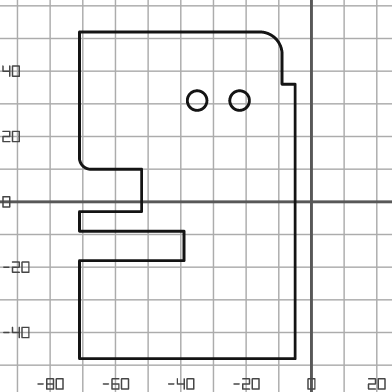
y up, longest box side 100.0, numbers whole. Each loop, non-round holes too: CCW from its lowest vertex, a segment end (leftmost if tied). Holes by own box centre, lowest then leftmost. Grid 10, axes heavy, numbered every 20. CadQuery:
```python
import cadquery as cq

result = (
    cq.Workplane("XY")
    .moveTo(-71.0, -48.0)
    .lineTo(-5.0, -48.0)
    .lineTo(-5.0, 36.0)
    .lineTo(-9.0, 36.0)
    .lineTo(-9.0, 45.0)
    .threePointArc((-11.0, 50.0), (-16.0, 52.0))
    .lineTo(-71.0, 52.0)
    .lineTo(-71.0, 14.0)
    .threePointArc((-70.0, 11.0), (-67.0, 10.0))
    .lineTo(-52.0, 10.0)
    .lineTo(-52.0, -3.0)
    .lineTo(-71.0, -3.0)
    .lineTo(-71.0, -9.0)
    .lineTo(-39.0, -9.0)
    .lineTo(-39.0, -18.0)
    .lineTo(-71.0, -18.0)
    .close()
    .moveTo(-35.0, 31.0)
    .circle(3.0)
    .moveTo(-22.0, 31.0)
    .circle(3.0)
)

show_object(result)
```